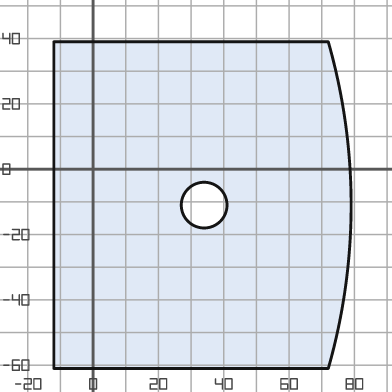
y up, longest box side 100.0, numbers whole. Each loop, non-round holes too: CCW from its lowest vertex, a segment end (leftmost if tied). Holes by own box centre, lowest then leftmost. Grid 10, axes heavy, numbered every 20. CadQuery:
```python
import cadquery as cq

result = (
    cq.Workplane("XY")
    .moveTo(-12.0, -61.0)
    .lineTo(72.0, -61.0)
    .threePointArc((79.0, -11.0), (72.0, 39.0))
    .lineTo(-12.0, 39.0)
    .close()
    .moveTo(34.0, -11.0)
    .circle(7.0)
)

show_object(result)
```